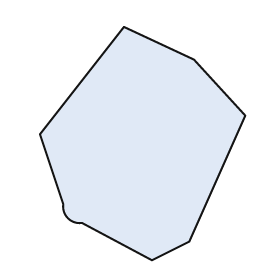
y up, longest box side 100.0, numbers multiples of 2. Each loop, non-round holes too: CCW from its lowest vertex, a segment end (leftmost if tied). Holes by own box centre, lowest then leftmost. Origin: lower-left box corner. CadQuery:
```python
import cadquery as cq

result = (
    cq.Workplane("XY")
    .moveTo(48.0, 0.0)
    .lineTo(64.0, 8.0)
    .lineTo(88.0, 62.0)
    .lineTo(66.0, 86.0)
    .lineTo(36.0, 100.0)
    .lineTo(0.0, 54.0)
    .lineTo(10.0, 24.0)
    .threePointArc((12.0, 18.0), (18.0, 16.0))
    .close()
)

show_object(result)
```